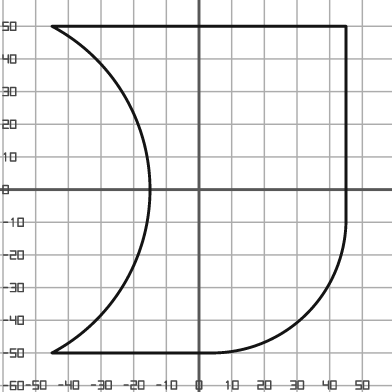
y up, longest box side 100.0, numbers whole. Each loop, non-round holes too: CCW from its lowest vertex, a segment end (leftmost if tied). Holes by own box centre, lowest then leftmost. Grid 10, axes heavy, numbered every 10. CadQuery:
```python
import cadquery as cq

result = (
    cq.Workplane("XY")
    .moveTo(-45.0, -50.0)
    .lineTo(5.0, -50.0)
    .threePointArc((33.0, -38.0), (45.0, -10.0))
    .lineTo(45.0, 50.0)
    .lineTo(-45.0, 50.0)
    .threePointArc((-15.0, 0.0), (-45.0, -50.0))
    .close()
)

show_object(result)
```